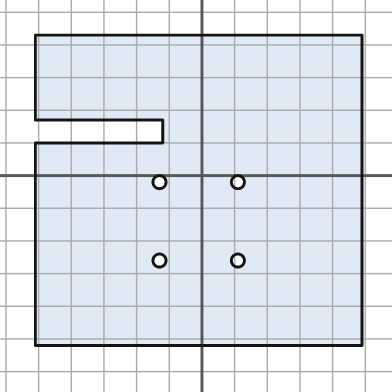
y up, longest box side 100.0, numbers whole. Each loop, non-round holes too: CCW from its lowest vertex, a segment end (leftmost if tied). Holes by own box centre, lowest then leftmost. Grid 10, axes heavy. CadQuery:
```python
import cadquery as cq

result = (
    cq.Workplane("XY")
    .moveTo(-51.0, -52.0)
    .lineTo(49.0, -52.0)
    .lineTo(49.0, 43.0)
    .lineTo(-51.0, 43.0)
    .lineTo(-51.0, 17.0)
    .lineTo(-12.0, 17.0)
    .lineTo(-12.0, 10.0)
    .lineTo(-51.0, 10.0)
    .close()
    .moveTo(-13.0, -26.0)
    .circle(2.0)
    .moveTo(11.0, -26.0)
    .circle(2.0)
    .moveTo(-13.0, -2.0)
    .circle(2.0)
    .moveTo(11.0, -2.0)
    .circle(2.0)
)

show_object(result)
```